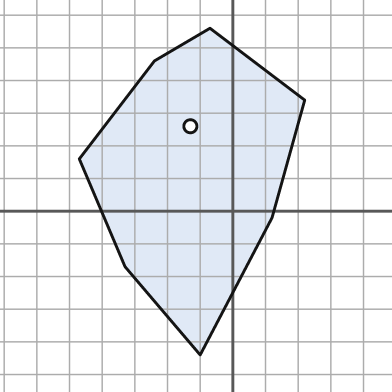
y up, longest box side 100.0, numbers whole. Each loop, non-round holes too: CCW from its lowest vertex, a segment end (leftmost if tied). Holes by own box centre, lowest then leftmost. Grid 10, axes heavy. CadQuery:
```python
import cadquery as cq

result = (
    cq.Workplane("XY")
    .moveTo(-10.0, -44.0)
    .lineTo(12.0, -2.0)
    .lineTo(22.0, 34.0)
    .lineTo(-7.0, 56.0)
    .lineTo(-24.0, 46.0)
    .lineTo(-47.0, 16.0)
    .lineTo(-33.0, -17.0)
    .close()
    .moveTo(-13.0, 26.0)
    .circle(2.0)
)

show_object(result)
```